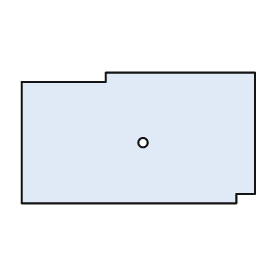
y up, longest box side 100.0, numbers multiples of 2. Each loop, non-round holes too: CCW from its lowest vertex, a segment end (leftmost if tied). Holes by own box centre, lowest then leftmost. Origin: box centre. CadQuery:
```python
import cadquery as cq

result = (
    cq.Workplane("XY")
    .moveTo(-50.0, -28.0)
    .lineTo(42.0, -28.0)
    .lineTo(42.0, -24.0)
    .lineTo(50.0, -24.0)
    .lineTo(50.0, 28.0)
    .lineTo(-14.0, 28.0)
    .lineTo(-14.0, 24.0)
    .lineTo(-50.0, 24.0)
    .close()
    .moveTo(2.0, -2.0)
    .circle(2.0)
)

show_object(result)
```